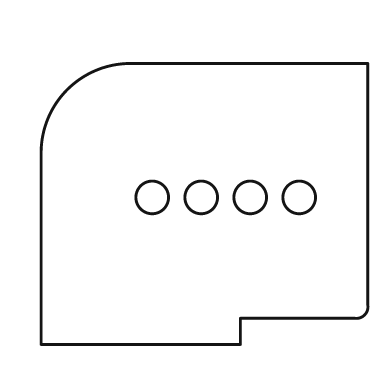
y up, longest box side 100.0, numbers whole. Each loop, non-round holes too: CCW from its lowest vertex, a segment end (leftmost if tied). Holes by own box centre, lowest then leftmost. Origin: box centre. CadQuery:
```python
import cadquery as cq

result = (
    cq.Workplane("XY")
    .moveTo(-50.0, -43.0)
    .lineTo(11.0, -43.0)
    .lineTo(11.0, -35.0)
    .lineTo(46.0, -35.0)
    .threePointArc((49.0, -34.0), (50.0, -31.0))
    .lineTo(50.0, 43.0)
    .lineTo(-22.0, 43.0)
    .threePointArc((-42.0, 35.0), (-50.0, 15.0))
    .close()
    .moveTo(-16.0, 2.0)
    .circle(5.0)
    .moveTo(-1.0, 2.0)
    .circle(5.0)
    .moveTo(14.0, 2.0)
    .circle(5.0)
    .moveTo(29.0, 2.0)
    .circle(5.0)
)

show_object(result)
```